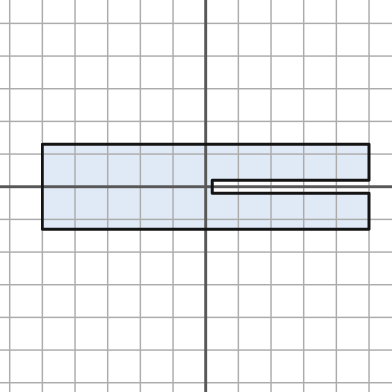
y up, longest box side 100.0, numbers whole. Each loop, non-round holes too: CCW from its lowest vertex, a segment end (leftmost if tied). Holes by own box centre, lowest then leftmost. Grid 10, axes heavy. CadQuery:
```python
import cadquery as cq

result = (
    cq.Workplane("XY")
    .moveTo(-50.0, -13.0)
    .lineTo(50.0, -13.0)
    .lineTo(50.0, -2.0)
    .lineTo(2.0, -2.0)
    .lineTo(2.0, 2.0)
    .lineTo(50.0, 2.0)
    .lineTo(50.0, 13.0)
    .lineTo(-50.0, 13.0)
    .close()
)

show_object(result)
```